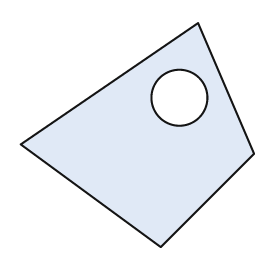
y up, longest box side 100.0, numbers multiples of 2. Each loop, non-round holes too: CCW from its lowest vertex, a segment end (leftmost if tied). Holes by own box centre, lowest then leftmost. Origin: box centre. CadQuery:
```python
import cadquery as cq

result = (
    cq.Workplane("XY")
    .moveTo(10.0, -48.0)
    .lineTo(50.0, -8.0)
    .lineTo(26.0, 48.0)
    .lineTo(-50.0, -4.0)
    .close()
    .moveTo(18.0, 16.0)
    .circle(12.0)
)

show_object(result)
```